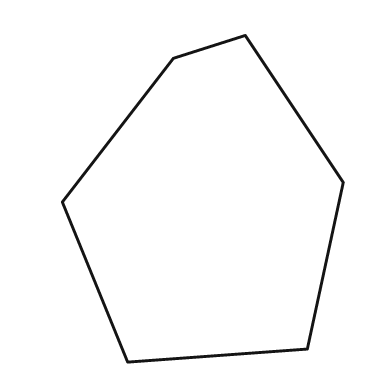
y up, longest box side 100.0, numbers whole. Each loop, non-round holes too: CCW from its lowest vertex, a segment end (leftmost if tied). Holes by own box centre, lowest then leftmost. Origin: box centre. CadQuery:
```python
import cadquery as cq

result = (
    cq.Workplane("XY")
    .moveTo(-23.0, -50.0)
    .lineTo(32.0, -46.0)
    .lineTo(43.0, 5.0)
    .lineTo(13.0, 50.0)
    .lineTo(-9.0, 43.0)
    .lineTo(-43.0, -1.0)
    .close()
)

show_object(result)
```